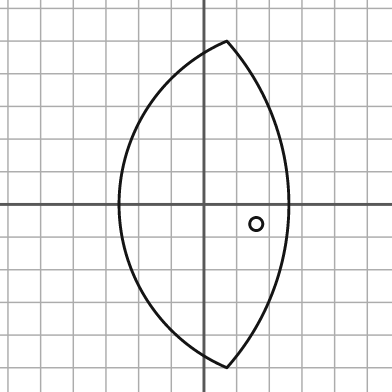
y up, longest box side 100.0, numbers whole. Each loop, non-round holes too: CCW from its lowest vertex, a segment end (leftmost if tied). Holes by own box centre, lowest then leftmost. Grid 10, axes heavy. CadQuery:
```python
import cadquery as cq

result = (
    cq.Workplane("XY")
    .moveTo(7.0, -50.0)
    .threePointArc((26.0, 0.0), (7.0, 50.0))
    .threePointArc((-26.0, 0.0), (7.0, -50.0))
    .close()
    .moveTo(16.0, -6.0)
    .circle(2.0)
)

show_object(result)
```